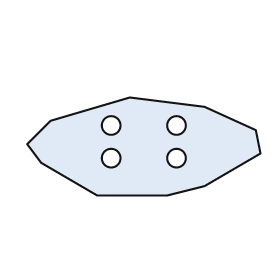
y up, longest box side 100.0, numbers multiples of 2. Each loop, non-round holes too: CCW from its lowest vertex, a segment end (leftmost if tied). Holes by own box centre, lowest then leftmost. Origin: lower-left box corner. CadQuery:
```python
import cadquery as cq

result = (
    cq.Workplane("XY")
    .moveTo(30.0, 0.0)
    .lineTo(60.0, 0.0)
    .lineTo(76.0, 4.0)
    .lineTo(100.0, 18.0)
    .lineTo(98.0, 28.0)
    .lineTo(76.0, 38.0)
    .lineTo(44.0, 42.0)
    .lineTo(10.0, 32.0)
    .lineTo(0.0, 22.0)
    .lineTo(6.0, 14.0)
    .close()
    .moveTo(36.0, 16.0)
    .circle(4.0)
    .moveTo(64.0, 16.0)
    .circle(4.0)
    .moveTo(36.0, 30.0)
    .circle(4.0)
    .moveTo(64.0, 30.0)
    .circle(4.0)
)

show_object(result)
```